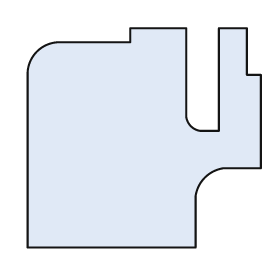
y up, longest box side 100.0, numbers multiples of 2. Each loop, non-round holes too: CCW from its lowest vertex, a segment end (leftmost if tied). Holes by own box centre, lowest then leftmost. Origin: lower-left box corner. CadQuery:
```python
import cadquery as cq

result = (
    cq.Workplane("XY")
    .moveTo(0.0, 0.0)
    .lineTo(72.0, 0.0)
    .lineTo(72.0, 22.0)
    .threePointArc((76.0, 30.0), (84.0, 34.0))
    .lineTo(100.0, 34.0)
    .lineTo(100.0, 74.0)
    .lineTo(94.0, 74.0)
    .lineTo(94.0, 94.0)
    .lineTo(82.0, 94.0)
    .lineTo(82.0, 50.0)
    .lineTo(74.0, 50.0)
    .threePointArc((70.0, 52.0), (68.0, 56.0))
    .lineTo(68.0, 94.0)
    .lineTo(44.0, 94.0)
    .lineTo(44.0, 88.0)
    .lineTo(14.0, 88.0)
    .threePointArc((4.0, 84.0), (0.0, 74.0))
    .close()
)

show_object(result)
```